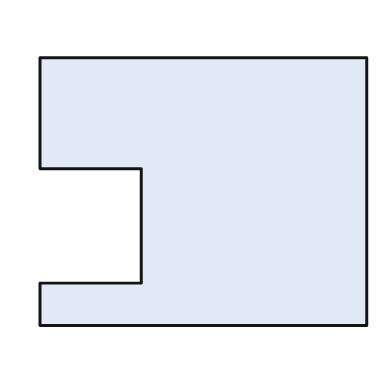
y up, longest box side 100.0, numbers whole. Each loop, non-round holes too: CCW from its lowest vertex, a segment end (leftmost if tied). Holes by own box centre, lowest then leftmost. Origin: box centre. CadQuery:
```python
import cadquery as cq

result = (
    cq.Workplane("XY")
    .moveTo(-50.0, -41.0)
    .lineTo(50.0, -41.0)
    .lineTo(50.0, 41.0)
    .lineTo(-50.0, 41.0)
    .lineTo(-50.0, 7.0)
    .lineTo(-19.0, 7.0)
    .lineTo(-19.0, -28.0)
    .lineTo(-50.0, -28.0)
    .close()
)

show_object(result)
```